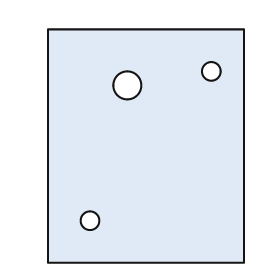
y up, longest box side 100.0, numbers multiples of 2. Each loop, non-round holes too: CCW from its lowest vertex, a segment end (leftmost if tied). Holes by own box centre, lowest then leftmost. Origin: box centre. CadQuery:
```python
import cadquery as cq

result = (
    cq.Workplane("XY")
    .moveTo(-42.0, -50.0)
    .lineTo(42.0, -50.0)
    .lineTo(42.0, 50.0)
    .lineTo(-42.0, 50.0)
    .close()
    .moveTo(-24.0, -32.0)
    .circle(4.0)
    .moveTo(-8.0, 26.0)
    .circle(6.0)
    .moveTo(28.0, 32.0)
    .circle(4.0)
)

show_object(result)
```